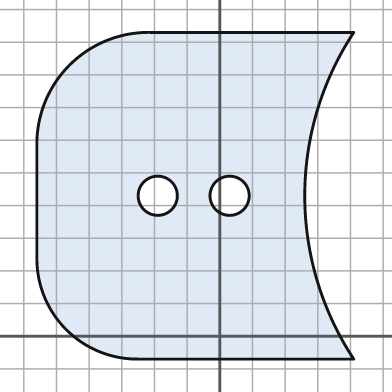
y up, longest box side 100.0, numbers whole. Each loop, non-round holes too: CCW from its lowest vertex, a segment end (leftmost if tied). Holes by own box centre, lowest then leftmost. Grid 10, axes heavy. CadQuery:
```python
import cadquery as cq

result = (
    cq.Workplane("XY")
    .moveTo(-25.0, -7.0)
    .lineTo(41.0, -7.0)
    .threePointArc((26.0, 43.0), (41.0, 93.0))
    .lineTo(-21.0, 93.0)
    .threePointArc((-46.0, 83.0), (-56.0, 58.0))
    .lineTo(-56.0, 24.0)
    .threePointArc((-47.0, 2.0), (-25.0, -7.0))
    .close()
    .moveTo(-19.0, 43.0)
    .circle(6.0)
    .moveTo(3.0, 43.0)
    .circle(6.0)
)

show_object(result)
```